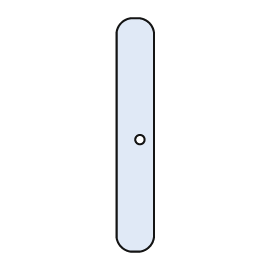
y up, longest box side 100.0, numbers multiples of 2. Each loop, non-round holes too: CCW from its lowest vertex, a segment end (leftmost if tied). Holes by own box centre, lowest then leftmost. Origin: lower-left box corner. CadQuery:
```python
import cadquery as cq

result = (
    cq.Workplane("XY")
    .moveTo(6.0, 0.0)
    .lineTo(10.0, 0.0)
    .threePointArc((14.0, 2.0), (16.0, 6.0))
    .lineTo(16.0, 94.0)
    .threePointArc((14.0, 98.0), (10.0, 100.0))
    .lineTo(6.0, 100.0)
    .threePointArc((2.0, 98.0), (0.0, 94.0))
    .lineTo(0.0, 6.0)
    .threePointArc((2.0, 2.0), (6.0, 0.0))
    .close()
    .moveTo(10.0, 48.0)
    .circle(2.0)
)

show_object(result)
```